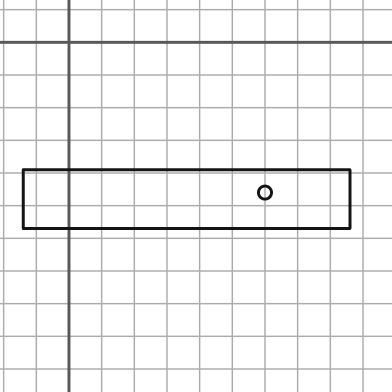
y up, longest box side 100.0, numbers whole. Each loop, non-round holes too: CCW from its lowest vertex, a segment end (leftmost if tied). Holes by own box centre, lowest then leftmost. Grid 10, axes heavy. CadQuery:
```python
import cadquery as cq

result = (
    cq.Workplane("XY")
    .moveTo(-14.0, -57.0)
    .lineTo(86.0, -57.0)
    .lineTo(86.0, -39.0)
    .lineTo(-14.0, -39.0)
    .close()
    .moveTo(60.0, -46.0)
    .circle(2.0)
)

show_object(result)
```